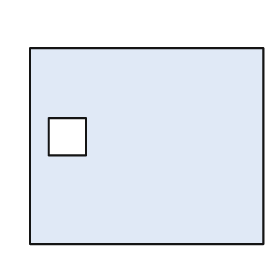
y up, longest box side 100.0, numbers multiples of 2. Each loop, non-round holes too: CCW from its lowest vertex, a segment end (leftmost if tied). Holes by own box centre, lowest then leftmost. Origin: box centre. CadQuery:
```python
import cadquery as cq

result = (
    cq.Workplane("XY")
    .moveTo(-50.0, -42.0)
    .lineTo(50.0, -42.0)
    .lineTo(50.0, 42.0)
    .lineTo(-50.0, 42.0)
    .close()
    .moveTo(-42.0, -4.0)
    .lineTo(-26.0, -4.0)
    .lineTo(-26.0, 12.0)
    .lineTo(-42.0, 12.0)
    .close()
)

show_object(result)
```